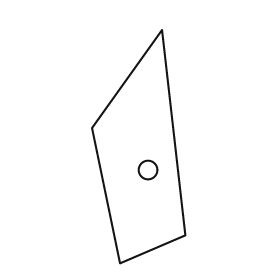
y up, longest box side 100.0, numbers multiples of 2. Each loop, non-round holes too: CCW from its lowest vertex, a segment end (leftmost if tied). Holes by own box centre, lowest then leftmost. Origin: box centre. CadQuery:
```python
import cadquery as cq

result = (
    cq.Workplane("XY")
    .moveTo(-8.0, -50.0)
    .lineTo(20.0, -38.0)
    .lineTo(10.0, 50.0)
    .lineTo(-20.0, 8.0)
    .close()
    .moveTo(4.0, -10.0)
    .circle(4.0)
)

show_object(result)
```